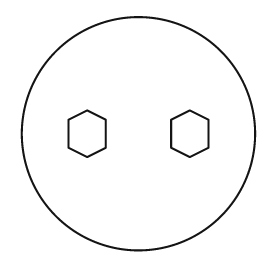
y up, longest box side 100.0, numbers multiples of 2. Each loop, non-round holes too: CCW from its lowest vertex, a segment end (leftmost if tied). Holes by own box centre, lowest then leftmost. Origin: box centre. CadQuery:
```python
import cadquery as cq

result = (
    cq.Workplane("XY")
    .moveTo(0.0, 0.0)
    .circle(50.0)
    .moveTo(-22.0, -10.0)
    .lineTo(-14.0, -6.0)
    .lineTo(-14.0, 6.0)
    .lineTo(-22.0, 10.0)
    .lineTo(-30.0, 6.0)
    .lineTo(-30.0, -6.0)
    .close()
    .moveTo(22.0, -10.0)
    .lineTo(30.0, -6.0)
    .lineTo(30.0, 6.0)
    .lineTo(22.0, 10.0)
    .lineTo(14.0, 6.0)
    .lineTo(14.0, -6.0)
    .close()
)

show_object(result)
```